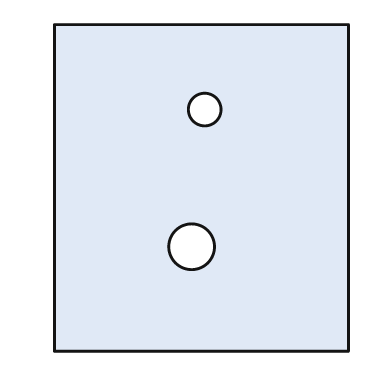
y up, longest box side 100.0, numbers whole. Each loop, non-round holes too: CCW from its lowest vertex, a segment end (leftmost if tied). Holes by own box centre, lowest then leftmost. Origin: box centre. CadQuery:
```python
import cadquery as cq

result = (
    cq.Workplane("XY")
    .moveTo(-45.0, -50.0)
    .lineTo(45.0, -50.0)
    .lineTo(45.0, 50.0)
    .lineTo(-45.0, 50.0)
    .close()
    .moveTo(-3.0, -18.0)
    .circle(7.0)
    .moveTo(1.0, 24.0)
    .circle(5.0)
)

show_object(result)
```